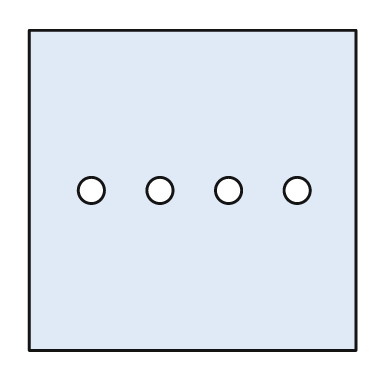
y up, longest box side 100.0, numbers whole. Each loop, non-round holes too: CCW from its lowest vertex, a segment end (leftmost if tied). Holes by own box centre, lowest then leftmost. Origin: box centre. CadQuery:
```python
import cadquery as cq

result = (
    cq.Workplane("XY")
    .moveTo(-50.0, -49.0)
    .lineTo(50.0, -49.0)
    .lineTo(50.0, 49.0)
    .lineTo(-50.0, 49.0)
    .close()
    .moveTo(-31.0, 0.0)
    .circle(4.0)
    .moveTo(-10.0, 0.0)
    .circle(4.0)
    .moveTo(11.0, 0.0)
    .circle(4.0)
    .moveTo(32.0, 0.0)
    .circle(4.0)
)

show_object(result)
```